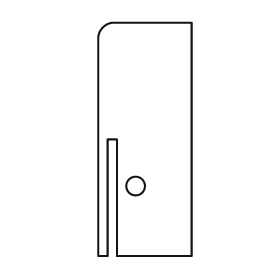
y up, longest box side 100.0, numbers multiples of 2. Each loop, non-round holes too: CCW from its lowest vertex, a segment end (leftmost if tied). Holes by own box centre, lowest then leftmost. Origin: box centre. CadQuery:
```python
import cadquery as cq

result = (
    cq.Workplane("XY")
    .moveTo(-20.0, -50.0)
    .lineTo(-16.0, -50.0)
    .lineTo(-16.0, 0.0)
    .lineTo(-12.0, 0.0)
    .lineTo(-12.0, -50.0)
    .lineTo(20.0, -50.0)
    .lineTo(20.0, 50.0)
    .lineTo(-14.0, 50.0)
    .threePointArc((-18.0, 48.0), (-20.0, 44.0))
    .close()
    .moveTo(-4.0, -20.0)
    .circle(4.0)
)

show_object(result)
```